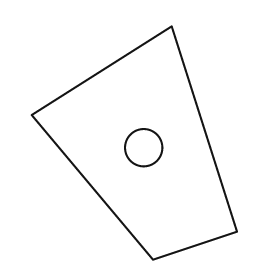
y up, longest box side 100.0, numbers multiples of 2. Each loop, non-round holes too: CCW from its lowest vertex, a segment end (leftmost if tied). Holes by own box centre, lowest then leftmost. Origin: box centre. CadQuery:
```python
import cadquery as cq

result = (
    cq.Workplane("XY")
    .moveTo(8.0, -50.0)
    .lineTo(44.0, -38.0)
    .lineTo(16.0, 50.0)
    .lineTo(-44.0, 12.0)
    .close()
    .moveTo(4.0, -2.0)
    .circle(8.0)
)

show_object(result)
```